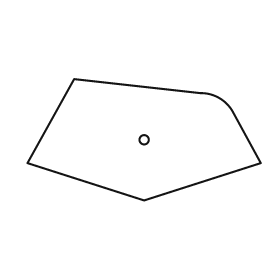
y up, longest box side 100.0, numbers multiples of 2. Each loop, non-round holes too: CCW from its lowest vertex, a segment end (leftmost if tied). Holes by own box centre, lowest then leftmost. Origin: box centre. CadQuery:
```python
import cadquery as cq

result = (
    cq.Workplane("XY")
    .moveTo(0.0, -26.0)
    .lineTo(50.0, -10.0)
    .lineTo(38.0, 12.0)
    .threePointArc((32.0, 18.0), (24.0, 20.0))
    .lineTo(-30.0, 26.0)
    .lineTo(-50.0, -10.0)
    .close()
    .moveTo(0.0, 0.0)
    .circle(2.0)
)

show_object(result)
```